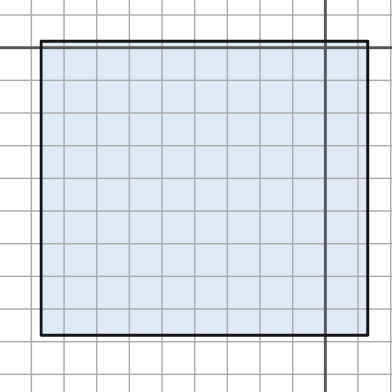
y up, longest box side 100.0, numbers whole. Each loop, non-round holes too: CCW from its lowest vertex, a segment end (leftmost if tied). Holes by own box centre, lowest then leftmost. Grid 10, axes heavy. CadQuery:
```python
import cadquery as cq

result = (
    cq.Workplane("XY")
    .moveTo(-87.0, -88.0)
    .lineTo(13.0, -88.0)
    .lineTo(13.0, 2.0)
    .lineTo(-87.0, 2.0)
    .close()
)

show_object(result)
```